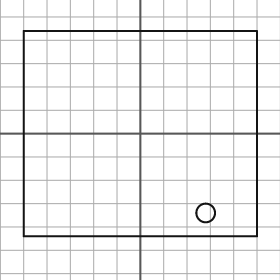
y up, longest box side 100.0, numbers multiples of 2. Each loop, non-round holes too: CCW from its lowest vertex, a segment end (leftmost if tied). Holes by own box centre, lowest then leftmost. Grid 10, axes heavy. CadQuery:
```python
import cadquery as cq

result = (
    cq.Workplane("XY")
    .moveTo(-50.0, -44.0)
    .lineTo(50.0, -44.0)
    .lineTo(50.0, 44.0)
    .lineTo(-50.0, 44.0)
    .close()
    .moveTo(28.0, -34.0)
    .circle(4.0)
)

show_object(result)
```